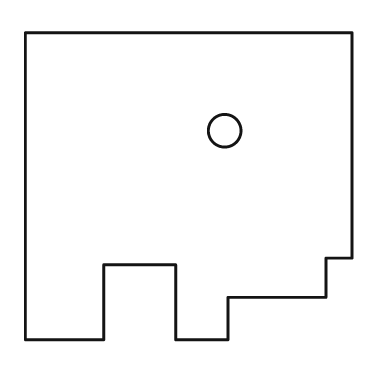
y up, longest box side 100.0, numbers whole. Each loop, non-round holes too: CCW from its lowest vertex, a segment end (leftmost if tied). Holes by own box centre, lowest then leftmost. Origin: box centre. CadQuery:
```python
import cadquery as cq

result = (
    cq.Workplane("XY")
    .moveTo(-50.0, -47.0)
    .lineTo(-26.0, -47.0)
    .lineTo(-26.0, -24.0)
    .lineTo(-4.0, -24.0)
    .lineTo(-4.0, -47.0)
    .lineTo(12.0, -47.0)
    .lineTo(12.0, -34.0)
    .lineTo(42.0, -34.0)
    .lineTo(42.0, -22.0)
    .lineTo(50.0, -22.0)
    .lineTo(50.0, 47.0)
    .lineTo(-50.0, 47.0)
    .close()
    .moveTo(11.0, 17.0)
    .circle(5.0)
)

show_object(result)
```